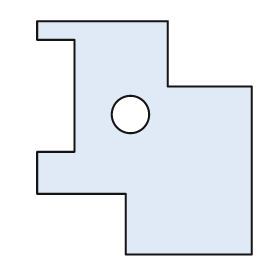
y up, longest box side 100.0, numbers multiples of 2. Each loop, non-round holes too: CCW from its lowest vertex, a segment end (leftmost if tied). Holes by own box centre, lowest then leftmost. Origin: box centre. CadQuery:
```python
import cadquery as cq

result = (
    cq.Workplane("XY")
    .moveTo(-8.0, -50.0)
    .lineTo(46.0, -50.0)
    .lineTo(46.0, 22.0)
    .lineTo(10.0, 22.0)
    .lineTo(10.0, 50.0)
    .lineTo(-46.0, 50.0)
    .lineTo(-46.0, 42.0)
    .lineTo(-30.0, 42.0)
    .lineTo(-30.0, -6.0)
    .lineTo(-46.0, -6.0)
    .lineTo(-46.0, -24.0)
    .lineTo(-8.0, -24.0)
    .close()
    .moveTo(-6.0, 10.0)
    .circle(8.0)
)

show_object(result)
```